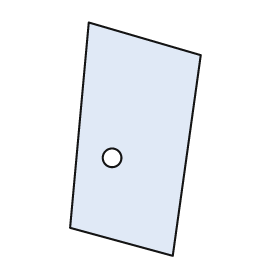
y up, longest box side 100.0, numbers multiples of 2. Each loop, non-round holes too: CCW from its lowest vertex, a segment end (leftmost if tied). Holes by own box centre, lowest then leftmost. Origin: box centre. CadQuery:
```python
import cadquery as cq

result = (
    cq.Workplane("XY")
    .moveTo(16.0, -50.0)
    .lineTo(28.0, 36.0)
    .lineTo(-20.0, 50.0)
    .lineTo(-28.0, -38.0)
    .close()
    .moveTo(-10.0, -8.0)
    .circle(4.0)
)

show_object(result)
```